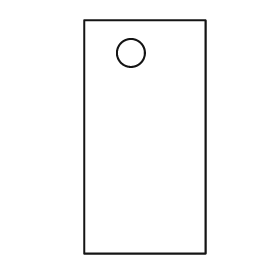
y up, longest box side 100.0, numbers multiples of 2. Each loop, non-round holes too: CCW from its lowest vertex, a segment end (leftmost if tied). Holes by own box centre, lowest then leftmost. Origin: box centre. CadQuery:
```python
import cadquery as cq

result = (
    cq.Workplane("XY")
    .moveTo(-26.0, -50.0)
    .lineTo(26.0, -50.0)
    .lineTo(26.0, 50.0)
    .lineTo(-26.0, 50.0)
    .close()
    .moveTo(-6.0, 36.0)
    .circle(6.0)
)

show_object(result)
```